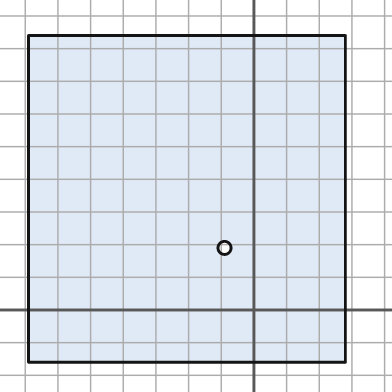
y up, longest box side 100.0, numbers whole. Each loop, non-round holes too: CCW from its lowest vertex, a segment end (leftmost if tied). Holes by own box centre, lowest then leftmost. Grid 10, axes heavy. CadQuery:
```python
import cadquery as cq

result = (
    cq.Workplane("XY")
    .moveTo(-69.0, -16.0)
    .lineTo(28.0, -16.0)
    .lineTo(28.0, 84.0)
    .lineTo(-69.0, 84.0)
    .close()
    .moveTo(-9.0, 19.0)
    .circle(2.0)
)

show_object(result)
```